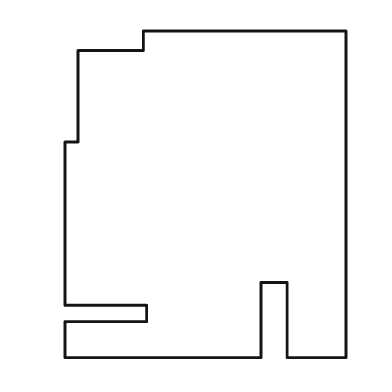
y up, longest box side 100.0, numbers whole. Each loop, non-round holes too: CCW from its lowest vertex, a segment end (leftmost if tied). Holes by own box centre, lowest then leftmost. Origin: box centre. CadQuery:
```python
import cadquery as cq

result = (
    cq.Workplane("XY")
    .moveTo(-43.0, -50.0)
    .lineTo(17.0, -50.0)
    .lineTo(17.0, -27.0)
    .lineTo(25.0, -27.0)
    .lineTo(25.0, -50.0)
    .lineTo(43.0, -50.0)
    .lineTo(43.0, 50.0)
    .lineTo(-19.0, 50.0)
    .lineTo(-19.0, 44.0)
    .lineTo(-39.0, 44.0)
    .lineTo(-39.0, 16.0)
    .lineTo(-43.0, 16.0)
    .lineTo(-43.0, -34.0)
    .lineTo(-18.0, -34.0)
    .lineTo(-18.0, -39.0)
    .lineTo(-43.0, -39.0)
    .close()
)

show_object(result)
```